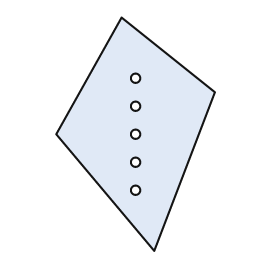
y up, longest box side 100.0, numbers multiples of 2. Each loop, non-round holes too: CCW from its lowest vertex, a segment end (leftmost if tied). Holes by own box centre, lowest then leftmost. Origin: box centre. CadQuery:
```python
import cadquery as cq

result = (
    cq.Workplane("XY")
    .moveTo(8.0, -50.0)
    .lineTo(34.0, 18.0)
    .lineTo(-6.0, 50.0)
    .lineTo(-34.0, 0.0)
    .close()
    .moveTo(0.0, -24.0)
    .circle(2.0)
    .moveTo(0.0, -12.0)
    .circle(2.0)
    .moveTo(0.0, 0.0)
    .circle(2.0)
    .moveTo(0.0, 12.0)
    .circle(2.0)
    .moveTo(0.0, 24.0)
    .circle(2.0)
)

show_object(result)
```